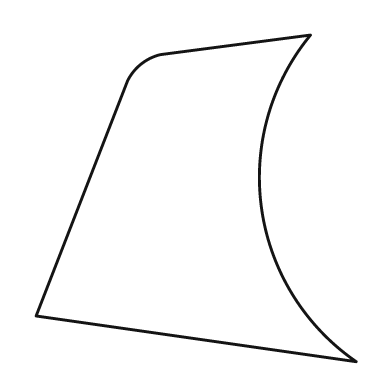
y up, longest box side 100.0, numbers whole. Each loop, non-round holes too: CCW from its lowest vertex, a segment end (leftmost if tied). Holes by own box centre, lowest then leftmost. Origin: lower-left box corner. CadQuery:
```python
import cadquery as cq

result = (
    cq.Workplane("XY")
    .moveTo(98.0, 0.0)
    .threePointArc((69.0, 47.0), (84.0, 100.0))
    .lineTo(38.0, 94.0)
    .threePointArc((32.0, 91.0), (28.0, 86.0))
    .lineTo(0.0, 14.0)
    .close()
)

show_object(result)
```